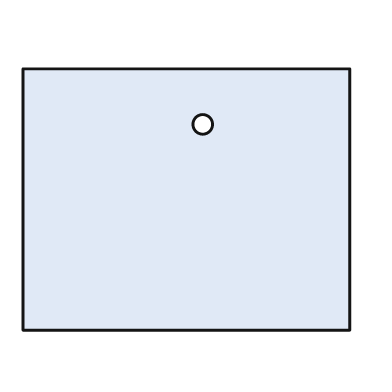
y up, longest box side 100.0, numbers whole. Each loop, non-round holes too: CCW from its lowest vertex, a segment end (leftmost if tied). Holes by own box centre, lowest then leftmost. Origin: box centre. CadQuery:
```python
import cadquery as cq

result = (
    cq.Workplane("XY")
    .moveTo(-50.0, -40.0)
    .lineTo(50.0, -40.0)
    .lineTo(50.0, 40.0)
    .lineTo(-50.0, 40.0)
    .close()
    .moveTo(5.0, 23.0)
    .circle(3.0)
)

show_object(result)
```